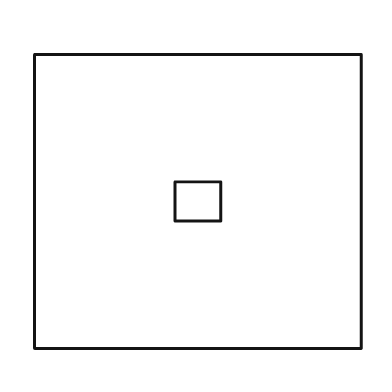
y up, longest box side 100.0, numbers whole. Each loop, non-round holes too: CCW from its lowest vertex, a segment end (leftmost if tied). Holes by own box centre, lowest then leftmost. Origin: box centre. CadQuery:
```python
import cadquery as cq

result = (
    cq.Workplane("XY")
    .moveTo(-50.0, -45.0)
    .lineTo(50.0, -45.0)
    .lineTo(50.0, 45.0)
    .lineTo(-50.0, 45.0)
    .close()
    .moveTo(-7.0, -6.0)
    .lineTo(7.0, -6.0)
    .lineTo(7.0, 6.0)
    .lineTo(-7.0, 6.0)
    .close()
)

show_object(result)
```